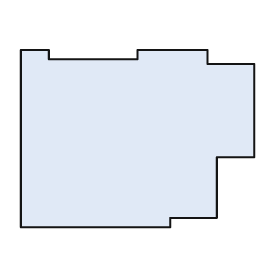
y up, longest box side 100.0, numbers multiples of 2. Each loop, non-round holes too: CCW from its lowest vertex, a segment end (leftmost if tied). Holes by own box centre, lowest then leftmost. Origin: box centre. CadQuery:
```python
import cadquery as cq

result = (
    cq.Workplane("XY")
    .moveTo(-50.0, -38.0)
    .lineTo(14.0, -38.0)
    .lineTo(14.0, -34.0)
    .lineTo(34.0, -34.0)
    .lineTo(34.0, -8.0)
    .lineTo(50.0, -8.0)
    .lineTo(50.0, 32.0)
    .lineTo(30.0, 32.0)
    .lineTo(30.0, 38.0)
    .lineTo(0.0, 38.0)
    .lineTo(0.0, 34.0)
    .lineTo(-38.0, 34.0)
    .lineTo(-38.0, 38.0)
    .lineTo(-50.0, 38.0)
    .close()
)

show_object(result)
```